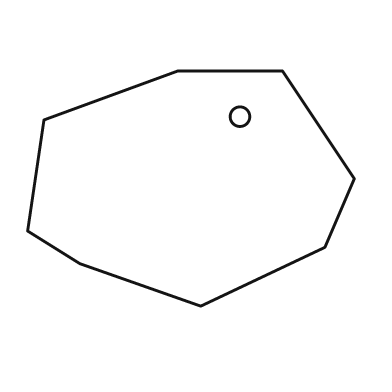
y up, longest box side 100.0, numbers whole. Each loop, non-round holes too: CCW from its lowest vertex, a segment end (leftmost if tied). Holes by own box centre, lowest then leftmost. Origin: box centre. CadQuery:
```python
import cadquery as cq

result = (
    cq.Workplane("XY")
    .moveTo(3.0, -36.0)
    .lineTo(41.0, -18.0)
    .lineTo(50.0, 3.0)
    .lineTo(28.0, 36.0)
    .lineTo(-4.0, 36.0)
    .lineTo(-45.0, 21.0)
    .lineTo(-50.0, -13.0)
    .lineTo(-34.0, -23.0)
    .close()
    .moveTo(15.0, 22.0)
    .circle(3.0)
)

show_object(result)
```